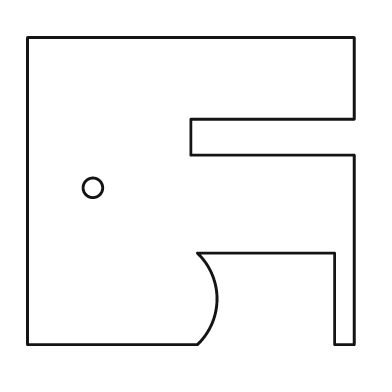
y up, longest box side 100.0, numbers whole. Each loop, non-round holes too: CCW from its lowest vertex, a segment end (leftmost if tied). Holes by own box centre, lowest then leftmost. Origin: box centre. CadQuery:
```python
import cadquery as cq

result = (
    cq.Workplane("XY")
    .moveTo(-50.0, -47.0)
    .lineTo(2.0, -47.0)
    .threePointArc((8.0, -33.0), (2.0, -19.0))
    .lineTo(44.0, -19.0)
    .lineTo(44.0, -47.0)
    .lineTo(50.0, -47.0)
    .lineTo(50.0, 11.0)
    .lineTo(0.0, 11.0)
    .lineTo(0.0, 22.0)
    .lineTo(50.0, 22.0)
    .lineTo(50.0, 47.0)
    .lineTo(-50.0, 47.0)
    .close()
    .moveTo(-30.0, 1.0)
    .circle(3.0)
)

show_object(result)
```